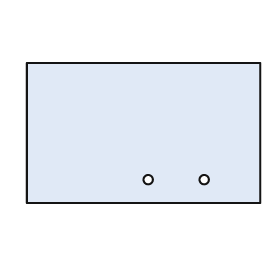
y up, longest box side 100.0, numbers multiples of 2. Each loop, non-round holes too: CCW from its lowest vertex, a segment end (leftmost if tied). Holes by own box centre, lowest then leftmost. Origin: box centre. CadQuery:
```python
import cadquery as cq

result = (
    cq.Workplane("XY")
    .moveTo(-50.0, -30.0)
    .lineTo(50.0, -30.0)
    .lineTo(50.0, 30.0)
    .lineTo(-50.0, 30.0)
    .close()
    .moveTo(2.0, -20.0)
    .circle(2.0)
    .moveTo(26.0, -20.0)
    .circle(2.0)
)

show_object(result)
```